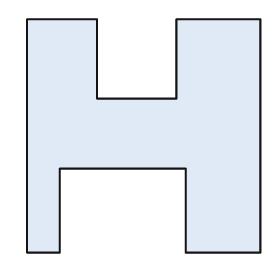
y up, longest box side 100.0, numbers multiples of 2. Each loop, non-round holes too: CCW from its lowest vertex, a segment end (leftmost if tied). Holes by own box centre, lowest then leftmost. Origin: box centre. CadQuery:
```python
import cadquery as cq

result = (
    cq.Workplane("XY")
    .moveTo(-50.0, -50.0)
    .lineTo(-36.0, -50.0)
    .lineTo(-36.0, -14.0)
    .lineTo(18.0, -14.0)
    .lineTo(18.0, -50.0)
    .lineTo(50.0, -50.0)
    .lineTo(50.0, 50.0)
    .lineTo(14.0, 50.0)
    .lineTo(14.0, 16.0)
    .lineTo(-20.0, 16.0)
    .lineTo(-20.0, 50.0)
    .lineTo(-50.0, 50.0)
    .close()
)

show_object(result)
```